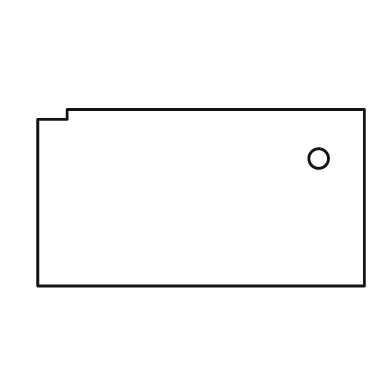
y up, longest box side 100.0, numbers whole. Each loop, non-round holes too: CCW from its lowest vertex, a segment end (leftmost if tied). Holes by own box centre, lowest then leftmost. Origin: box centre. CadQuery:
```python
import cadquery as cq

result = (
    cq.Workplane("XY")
    .moveTo(-50.0, -27.0)
    .lineTo(50.0, -27.0)
    .lineTo(50.0, 27.0)
    .lineTo(-41.0, 27.0)
    .lineTo(-41.0, 24.0)
    .lineTo(-50.0, 24.0)
    .close()
    .moveTo(36.0, 12.0)
    .circle(3.0)
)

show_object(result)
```